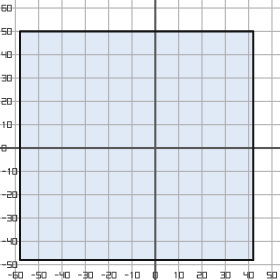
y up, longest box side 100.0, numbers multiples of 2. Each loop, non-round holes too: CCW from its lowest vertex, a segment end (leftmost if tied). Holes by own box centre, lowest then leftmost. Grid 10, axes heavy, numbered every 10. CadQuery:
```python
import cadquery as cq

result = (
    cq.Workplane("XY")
    .moveTo(-58.0, -48.0)
    .lineTo(42.0, -48.0)
    .lineTo(42.0, 50.0)
    .lineTo(-58.0, 50.0)
    .close()
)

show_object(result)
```